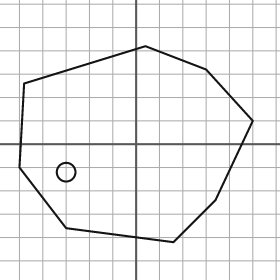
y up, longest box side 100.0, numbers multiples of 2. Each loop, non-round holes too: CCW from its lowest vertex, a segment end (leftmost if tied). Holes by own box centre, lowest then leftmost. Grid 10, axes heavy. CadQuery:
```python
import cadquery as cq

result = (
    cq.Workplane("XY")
    .moveTo(16.0, -42.0)
    .lineTo(34.0, -24.0)
    .lineTo(50.0, 10.0)
    .lineTo(30.0, 32.0)
    .lineTo(4.0, 42.0)
    .lineTo(-48.0, 26.0)
    .lineTo(-50.0, -10.0)
    .lineTo(-30.0, -36.0)
    .close()
    .moveTo(-30.0, -12.0)
    .circle(4.0)
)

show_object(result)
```